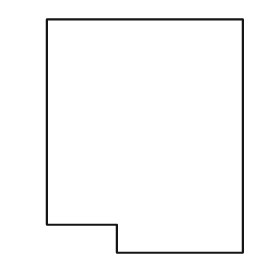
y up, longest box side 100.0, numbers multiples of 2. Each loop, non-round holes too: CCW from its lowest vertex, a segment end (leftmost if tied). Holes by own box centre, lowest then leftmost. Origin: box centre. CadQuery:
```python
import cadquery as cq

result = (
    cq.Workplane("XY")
    .moveTo(-12.0, -50.0)
    .lineTo(42.0, -50.0)
    .lineTo(42.0, 50.0)
    .lineTo(-42.0, 50.0)
    .lineTo(-42.0, -38.0)
    .lineTo(-12.0, -38.0)
    .close()
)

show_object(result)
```